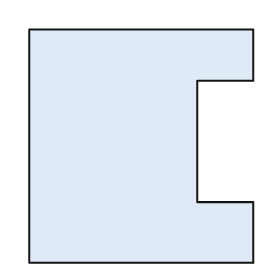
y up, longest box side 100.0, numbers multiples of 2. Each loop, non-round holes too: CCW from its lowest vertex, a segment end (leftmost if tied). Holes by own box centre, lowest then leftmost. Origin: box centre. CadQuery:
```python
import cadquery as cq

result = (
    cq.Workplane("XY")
    .moveTo(-48.0, -50.0)
    .lineTo(48.0, -50.0)
    .lineTo(48.0, -24.0)
    .lineTo(24.0, -24.0)
    .lineTo(24.0, 28.0)
    .lineTo(48.0, 28.0)
    .lineTo(48.0, 50.0)
    .lineTo(-48.0, 50.0)
    .close()
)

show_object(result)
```